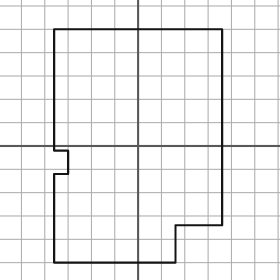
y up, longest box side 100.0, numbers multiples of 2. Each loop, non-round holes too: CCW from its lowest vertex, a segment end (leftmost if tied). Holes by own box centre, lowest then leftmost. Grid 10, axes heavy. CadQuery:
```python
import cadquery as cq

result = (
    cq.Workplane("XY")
    .moveTo(-36.0, -50.0)
    .lineTo(16.0, -50.0)
    .lineTo(16.0, -34.0)
    .lineTo(36.0, -34.0)
    .lineTo(36.0, 50.0)
    .lineTo(-36.0, 50.0)
    .lineTo(-36.0, -2.0)
    .lineTo(-30.0, -2.0)
    .lineTo(-30.0, -12.0)
    .lineTo(-36.0, -12.0)
    .close()
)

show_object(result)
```